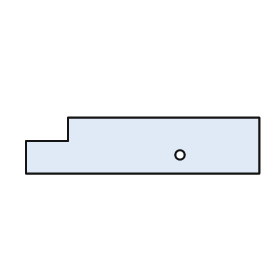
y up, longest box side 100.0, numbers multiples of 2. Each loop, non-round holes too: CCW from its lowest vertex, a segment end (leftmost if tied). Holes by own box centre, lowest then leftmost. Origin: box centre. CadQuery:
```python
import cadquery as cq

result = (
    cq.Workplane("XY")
    .moveTo(-50.0, -12.0)
    .lineTo(50.0, -12.0)
    .lineTo(50.0, 12.0)
    .lineTo(-32.0, 12.0)
    .lineTo(-32.0, 2.0)
    .lineTo(-50.0, 2.0)
    .close()
    .moveTo(16.0, -4.0)
    .circle(2.0)
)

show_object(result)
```